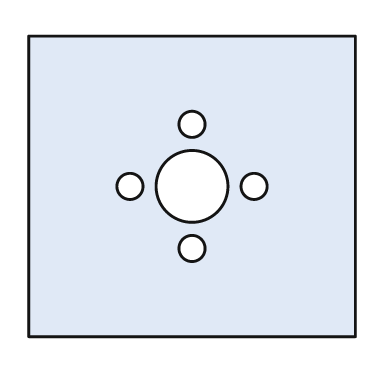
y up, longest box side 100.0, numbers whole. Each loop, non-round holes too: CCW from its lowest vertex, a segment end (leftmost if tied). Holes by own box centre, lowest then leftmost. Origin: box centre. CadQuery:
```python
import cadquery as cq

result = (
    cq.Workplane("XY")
    .moveTo(-50.0, -46.0)
    .lineTo(50.0, -46.0)
    .lineTo(50.0, 46.0)
    .lineTo(-50.0, 46.0)
    .close()
    .moveTo(0.0, -19.0)
    .circle(4.0)
    .moveTo(-19.0, 0.0)
    .circle(4.0)
    .moveTo(0.0, 0.0)
    .circle(11.0)
    .moveTo(19.0, 0.0)
    .circle(4.0)
    .moveTo(0.0, 19.0)
    .circle(4.0)
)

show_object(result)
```